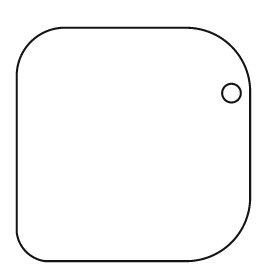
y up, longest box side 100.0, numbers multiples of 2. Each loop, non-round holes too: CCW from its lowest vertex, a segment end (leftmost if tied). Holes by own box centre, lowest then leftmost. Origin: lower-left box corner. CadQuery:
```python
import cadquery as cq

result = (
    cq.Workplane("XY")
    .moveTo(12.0, 0.0)
    .lineTo(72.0, 0.0)
    .threePointArc((92.0, 8.0), (100.0, 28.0))
    .lineTo(100.0, 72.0)
    .threePointArc((92.0, 92.0), (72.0, 100.0))
    .lineTo(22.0, 100.0)
    .threePointArc((6.0, 94.0), (0.0, 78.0))
    .lineTo(0.0, 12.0)
    .threePointArc((4.0, 4.0), (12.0, 0.0))
    .close()
    .moveTo(92.0, 72.0)
    .circle(4.0)
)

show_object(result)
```